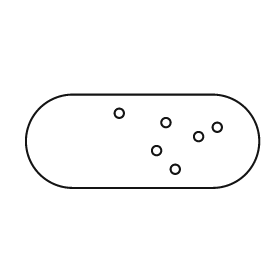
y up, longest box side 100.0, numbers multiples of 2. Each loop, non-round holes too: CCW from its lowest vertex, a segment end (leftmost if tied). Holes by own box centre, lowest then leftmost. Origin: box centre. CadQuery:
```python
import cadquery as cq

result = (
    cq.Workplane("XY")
    .moveTo(-30.0, -20.0)
    .lineTo(30.0, -20.0)
    .threePointArc((50.0, 0.0), (30.0, 20.0))
    .lineTo(-30.0, 20.0)
    .threePointArc((-50.0, 0.0), (-30.0, -20.0))
    .close()
    .moveTo(14.0, -12.0)
    .circle(2.0)
    .moveTo(6.0, -4.0)
    .circle(2.0)
    .moveTo(24.0, 2.0)
    .circle(2.0)
    .moveTo(32.0, 6.0)
    .circle(2.0)
    .moveTo(10.0, 8.0)
    .circle(2.0)
    .moveTo(-10.0, 12.0)
    .circle(2.0)
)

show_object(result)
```